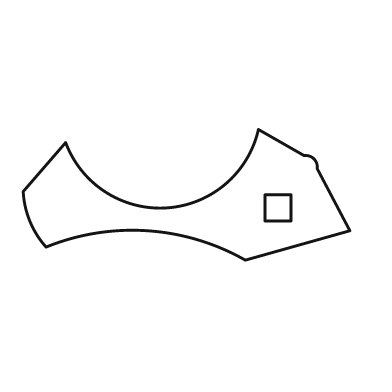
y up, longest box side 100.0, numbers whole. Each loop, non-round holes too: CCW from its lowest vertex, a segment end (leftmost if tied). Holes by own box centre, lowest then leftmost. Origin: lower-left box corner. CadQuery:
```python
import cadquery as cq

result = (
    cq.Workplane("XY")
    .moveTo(68.0, 0.0)
    .lineTo(100.0, 9.0)
    .lineTo(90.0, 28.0)
    .threePointArc((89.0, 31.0), (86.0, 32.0))
    .lineTo(72.0, 40.0)
    .threePointArc((44.0, 16.0), (13.0, 36.0))
    .lineTo(0.0, 21.0)
    .threePointArc((2.0, 12.0), (7.0, 4.0))
    .threePointArc((38.0, 9.0), (68.0, 0.0))
    .close()
    .moveTo(74.0, 12.0)
    .lineTo(82.0, 12.0)
    .lineTo(82.0, 20.0)
    .lineTo(74.0, 20.0)
    .close()
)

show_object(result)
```